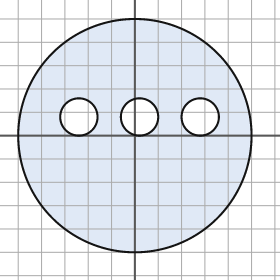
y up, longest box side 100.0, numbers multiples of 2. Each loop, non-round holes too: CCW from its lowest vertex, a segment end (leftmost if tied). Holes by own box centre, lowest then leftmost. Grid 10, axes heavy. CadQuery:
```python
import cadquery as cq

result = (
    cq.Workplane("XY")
    .moveTo(0.0, 0.0)
    .circle(50.0)
    .moveTo(-24.0, 8.0)
    .circle(8.0)
    .moveTo(2.0, 8.0)
    .circle(8.0)
    .moveTo(28.0, 8.0)
    .circle(8.0)
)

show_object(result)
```